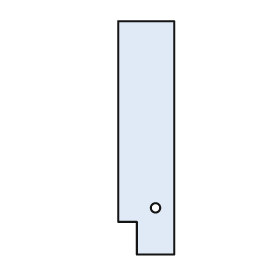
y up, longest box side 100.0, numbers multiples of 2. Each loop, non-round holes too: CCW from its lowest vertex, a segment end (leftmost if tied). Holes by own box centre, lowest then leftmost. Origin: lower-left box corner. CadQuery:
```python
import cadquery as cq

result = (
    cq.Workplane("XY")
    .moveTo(8.0, 0.0)
    .lineTo(24.0, 0.0)
    .lineTo(24.0, 100.0)
    .lineTo(0.0, 100.0)
    .lineTo(0.0, 14.0)
    .lineTo(8.0, 14.0)
    .close()
    .moveTo(16.0, 20.0)
    .circle(2.0)
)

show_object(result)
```